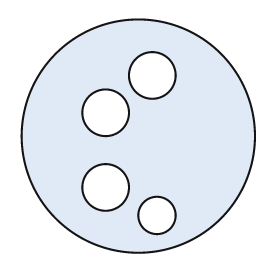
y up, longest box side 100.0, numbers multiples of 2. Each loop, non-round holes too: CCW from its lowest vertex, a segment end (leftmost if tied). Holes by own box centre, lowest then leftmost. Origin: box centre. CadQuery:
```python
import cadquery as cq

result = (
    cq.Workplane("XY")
    .moveTo(0.0, 0.0)
    .circle(50.0)
    .moveTo(8.0, -34.0)
    .circle(8.0)
    .moveTo(-14.0, -22.0)
    .circle(10.0)
    .moveTo(-14.0, 10.0)
    .circle(10.0)
    .moveTo(6.0, 26.0)
    .circle(10.0)
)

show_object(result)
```